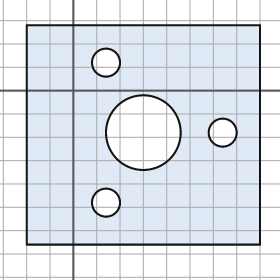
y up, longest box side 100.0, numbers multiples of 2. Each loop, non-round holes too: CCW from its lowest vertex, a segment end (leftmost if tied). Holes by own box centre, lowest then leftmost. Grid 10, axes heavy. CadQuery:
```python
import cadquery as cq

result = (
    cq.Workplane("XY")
    .moveTo(-20.0, -66.0)
    .lineTo(80.0, -66.0)
    .lineTo(80.0, 28.0)
    .lineTo(-20.0, 28.0)
    .close()
    .moveTo(14.0, -48.0)
    .circle(6.0)
    .moveTo(30.0, -18.0)
    .circle(16.0)
    .moveTo(64.0, -18.0)
    .circle(6.0)
    .moveTo(14.0, 12.0)
    .circle(6.0)
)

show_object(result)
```